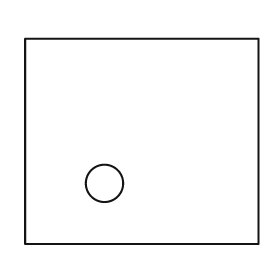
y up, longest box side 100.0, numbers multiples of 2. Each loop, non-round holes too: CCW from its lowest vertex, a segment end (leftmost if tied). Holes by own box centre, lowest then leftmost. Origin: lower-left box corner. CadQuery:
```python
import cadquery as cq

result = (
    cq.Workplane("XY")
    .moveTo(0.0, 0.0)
    .lineTo(100.0, 0.0)
    .lineTo(100.0, 88.0)
    .lineTo(0.0, 88.0)
    .close()
    .moveTo(34.0, 26.0)
    .circle(8.0)
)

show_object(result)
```